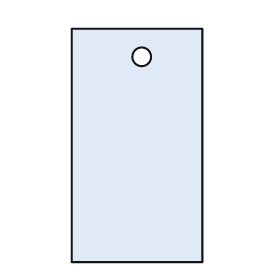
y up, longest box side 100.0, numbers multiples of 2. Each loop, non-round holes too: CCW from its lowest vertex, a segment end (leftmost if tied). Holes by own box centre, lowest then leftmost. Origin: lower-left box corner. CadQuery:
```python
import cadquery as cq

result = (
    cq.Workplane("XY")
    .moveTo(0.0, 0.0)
    .lineTo(56.0, 0.0)
    .lineTo(56.0, 100.0)
    .lineTo(0.0, 100.0)
    .close()
    .moveTo(30.0, 88.0)
    .circle(4.0)
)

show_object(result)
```